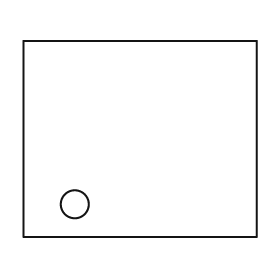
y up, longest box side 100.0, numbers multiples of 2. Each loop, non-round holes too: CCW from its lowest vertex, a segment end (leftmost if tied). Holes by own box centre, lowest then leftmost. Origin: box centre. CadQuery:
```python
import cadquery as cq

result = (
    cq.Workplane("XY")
    .moveTo(-50.0, -42.0)
    .lineTo(50.0, -42.0)
    .lineTo(50.0, 42.0)
    .lineTo(-50.0, 42.0)
    .close()
    .moveTo(-28.0, -28.0)
    .circle(6.0)
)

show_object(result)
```